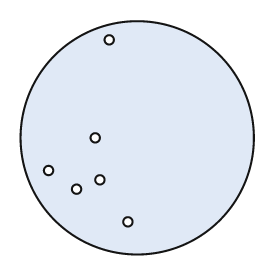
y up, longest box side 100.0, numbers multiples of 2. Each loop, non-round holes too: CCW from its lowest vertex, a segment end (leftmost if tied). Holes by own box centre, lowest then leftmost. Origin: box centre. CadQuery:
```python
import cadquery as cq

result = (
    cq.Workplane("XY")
    .moveTo(0.0, 0.0)
    .circle(50.0)
    .moveTo(-4.0, -36.0)
    .circle(2.0)
    .moveTo(-26.0, -22.0)
    .circle(2.0)
    .moveTo(-16.0, -18.0)
    .circle(2.0)
    .moveTo(-38.0, -14.0)
    .circle(2.0)
    .moveTo(-18.0, 0.0)
    .circle(2.0)
    .moveTo(-12.0, 42.0)
    .circle(2.0)
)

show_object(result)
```